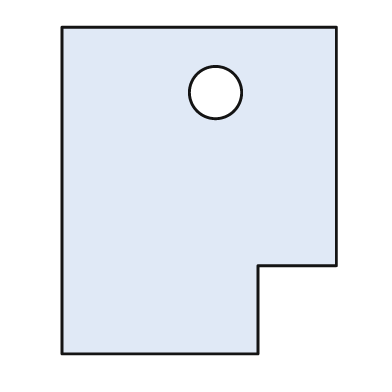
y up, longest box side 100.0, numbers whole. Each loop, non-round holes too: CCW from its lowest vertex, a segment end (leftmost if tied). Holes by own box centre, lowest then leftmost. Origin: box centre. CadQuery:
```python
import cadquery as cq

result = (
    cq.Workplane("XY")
    .moveTo(-42.0, -50.0)
    .lineTo(18.0, -50.0)
    .lineTo(18.0, -23.0)
    .lineTo(42.0, -23.0)
    .lineTo(42.0, 50.0)
    .lineTo(-42.0, 50.0)
    .close()
    .moveTo(5.0, 30.0)
    .circle(8.0)
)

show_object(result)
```